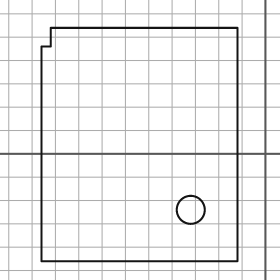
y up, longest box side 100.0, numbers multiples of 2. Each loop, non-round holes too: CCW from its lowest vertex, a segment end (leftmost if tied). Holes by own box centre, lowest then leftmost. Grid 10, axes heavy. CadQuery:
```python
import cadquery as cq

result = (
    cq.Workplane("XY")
    .moveTo(-96.0, -46.0)
    .lineTo(-12.0, -46.0)
    .lineTo(-12.0, 54.0)
    .lineTo(-92.0, 54.0)
    .lineTo(-92.0, 46.0)
    .lineTo(-96.0, 46.0)
    .close()
    .moveTo(-32.0, -24.0)
    .circle(6.0)
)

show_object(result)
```